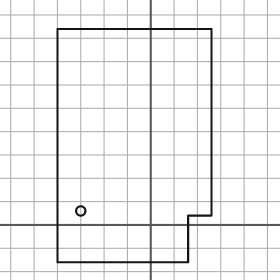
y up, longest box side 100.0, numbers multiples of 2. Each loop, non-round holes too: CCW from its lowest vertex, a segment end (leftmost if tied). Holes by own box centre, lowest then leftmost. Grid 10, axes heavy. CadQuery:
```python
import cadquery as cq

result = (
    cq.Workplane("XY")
    .moveTo(-40.0, -16.0)
    .lineTo(16.0, -16.0)
    .lineTo(16.0, 4.0)
    .lineTo(26.0, 4.0)
    .lineTo(26.0, 84.0)
    .lineTo(-40.0, 84.0)
    .close()
    .moveTo(-30.0, 6.0)
    .circle(2.0)
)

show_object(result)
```